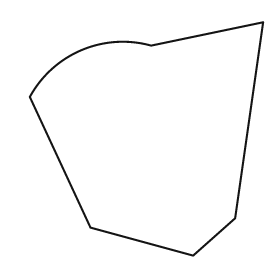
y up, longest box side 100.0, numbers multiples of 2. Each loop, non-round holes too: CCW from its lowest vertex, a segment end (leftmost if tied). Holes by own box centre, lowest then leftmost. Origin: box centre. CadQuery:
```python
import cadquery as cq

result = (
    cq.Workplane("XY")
    .moveTo(20.0, -50.0)
    .lineTo(38.0, -34.0)
    .lineTo(50.0, 50.0)
    .lineTo(2.0, 40.0)
    .threePointArc((-28.0, 38.0), (-50.0, 18.0))
    .lineTo(-24.0, -38.0)
    .close()
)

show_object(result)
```